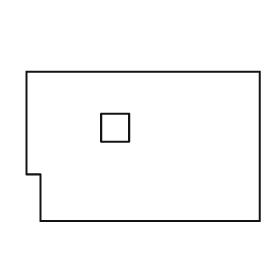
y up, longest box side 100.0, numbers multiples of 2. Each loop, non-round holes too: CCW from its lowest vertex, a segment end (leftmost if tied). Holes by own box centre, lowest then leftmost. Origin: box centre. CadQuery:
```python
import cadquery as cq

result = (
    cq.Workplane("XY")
    .moveTo(-44.0, -32.0)
    .lineTo(50.0, -32.0)
    .lineTo(50.0, 32.0)
    .lineTo(-50.0, 32.0)
    .lineTo(-50.0, -12.0)
    .lineTo(-44.0, -12.0)
    .close()
    .moveTo(-18.0, 2.0)
    .lineTo(-6.0, 2.0)
    .lineTo(-6.0, 14.0)
    .lineTo(-18.0, 14.0)
    .close()
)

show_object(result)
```